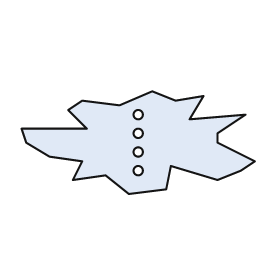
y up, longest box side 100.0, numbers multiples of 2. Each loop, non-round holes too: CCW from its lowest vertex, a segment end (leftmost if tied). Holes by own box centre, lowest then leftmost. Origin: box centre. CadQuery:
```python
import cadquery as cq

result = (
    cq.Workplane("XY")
    .moveTo(-4.0, -22.0)
    .lineTo(12.0, -20.0)
    .lineTo(14.0, -10.0)
    .lineTo(34.0, -16.0)
    .lineTo(44.0, -12.0)
    .lineTo(50.0, -8.0)
    .lineTo(34.0, 0.0)
    .lineTo(34.0, 4.0)
    .lineTo(46.0, 12.0)
    .lineTo(22.0, 10.0)
    .lineTo(28.0, 20.0)
    .lineTo(16.0, 18.0)
    .lineTo(6.0, 22.0)
    .lineTo(-8.0, 16.0)
    .lineTo(-24.0, 18.0)
    .lineTo(-30.0, 14.0)
    .lineTo(-22.0, 6.0)
    .lineTo(-50.0, 6.0)
    .lineTo(-48.0, 0.0)
    .lineTo(-38.0, -6.0)
    .lineTo(-24.0, -8.0)
    .lineTo(-28.0, -16.0)
    .lineTo(-14.0, -14.0)
    .close()
    .moveTo(0.0, -12.0)
    .circle(2.0)
    .moveTo(0.0, -4.0)
    .circle(2.0)
    .moveTo(0.0, 4.0)
    .circle(2.0)
    .moveTo(0.0, 12.0)
    .circle(2.0)
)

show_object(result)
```